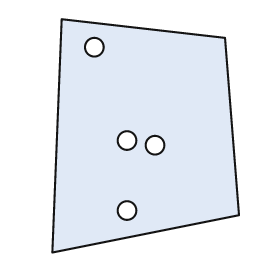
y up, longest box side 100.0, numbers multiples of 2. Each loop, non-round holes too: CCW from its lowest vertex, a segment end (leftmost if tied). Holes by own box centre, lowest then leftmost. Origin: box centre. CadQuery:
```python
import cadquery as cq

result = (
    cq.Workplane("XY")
    .moveTo(-40.0, -50.0)
    .lineTo(40.0, -34.0)
    .lineTo(34.0, 42.0)
    .lineTo(-36.0, 50.0)
    .close()
    .moveTo(-8.0, -32.0)
    .circle(4.0)
    .moveTo(4.0, -4.0)
    .circle(4.0)
    .moveTo(-8.0, -2.0)
    .circle(4.0)
    .moveTo(-22.0, 38.0)
    .circle(4.0)
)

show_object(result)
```